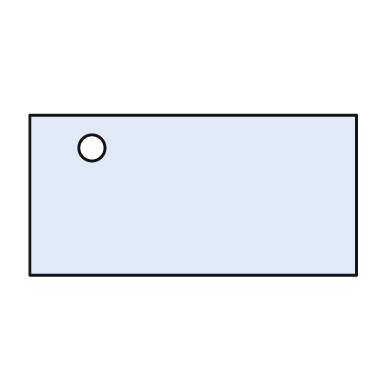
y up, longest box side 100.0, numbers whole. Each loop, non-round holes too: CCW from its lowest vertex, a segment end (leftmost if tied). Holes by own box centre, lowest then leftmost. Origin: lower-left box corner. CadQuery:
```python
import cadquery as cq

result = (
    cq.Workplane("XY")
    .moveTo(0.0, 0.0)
    .lineTo(100.0, 0.0)
    .lineTo(100.0, 49.0)
    .lineTo(0.0, 49.0)
    .close()
    .moveTo(19.0, 39.0)
    .circle(4.0)
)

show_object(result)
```